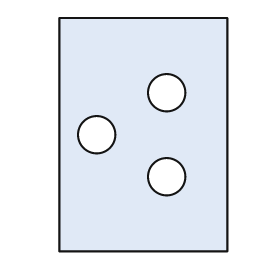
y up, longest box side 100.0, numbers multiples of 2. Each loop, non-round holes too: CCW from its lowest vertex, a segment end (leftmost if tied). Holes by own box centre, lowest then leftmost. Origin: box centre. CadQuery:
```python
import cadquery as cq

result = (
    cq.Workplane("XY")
    .moveTo(-36.0, -50.0)
    .lineTo(36.0, -50.0)
    .lineTo(36.0, 50.0)
    .lineTo(-36.0, 50.0)
    .close()
    .moveTo(10.0, -18.0)
    .circle(8.0)
    .moveTo(-20.0, 0.0)
    .circle(8.0)
    .moveTo(10.0, 18.0)
    .circle(8.0)
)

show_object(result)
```